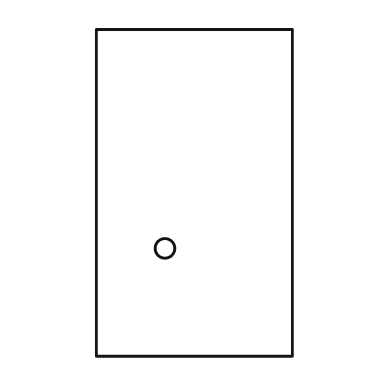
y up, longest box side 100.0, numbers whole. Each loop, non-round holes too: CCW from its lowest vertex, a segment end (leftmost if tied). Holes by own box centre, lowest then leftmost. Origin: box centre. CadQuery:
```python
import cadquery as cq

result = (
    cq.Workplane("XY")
    .moveTo(-30.0, -50.0)
    .lineTo(30.0, -50.0)
    .lineTo(30.0, 50.0)
    .lineTo(-30.0, 50.0)
    .close()
    .moveTo(-9.0, -17.0)
    .circle(3.0)
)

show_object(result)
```